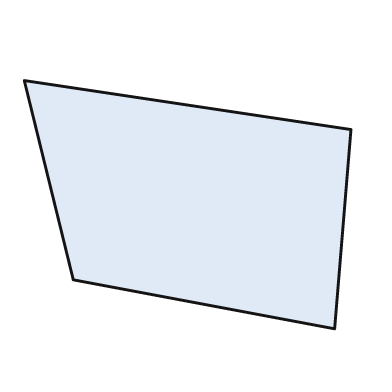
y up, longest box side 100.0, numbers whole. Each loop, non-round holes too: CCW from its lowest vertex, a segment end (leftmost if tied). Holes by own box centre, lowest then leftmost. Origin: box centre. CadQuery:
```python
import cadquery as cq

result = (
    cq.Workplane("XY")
    .moveTo(45.0, -38.0)
    .lineTo(50.0, 23.0)
    .lineTo(-50.0, 38.0)
    .lineTo(-35.0, -23.0)
    .close()
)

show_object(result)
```